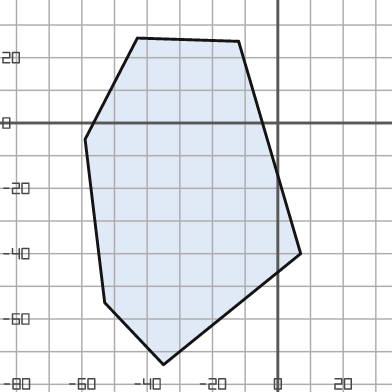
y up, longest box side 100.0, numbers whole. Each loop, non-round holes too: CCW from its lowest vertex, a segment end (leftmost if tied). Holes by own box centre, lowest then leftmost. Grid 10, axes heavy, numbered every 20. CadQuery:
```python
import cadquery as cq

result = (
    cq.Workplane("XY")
    .moveTo(-35.0, -74.0)
    .lineTo(7.0, -40.0)
    .lineTo(-12.0, 25.0)
    .lineTo(-43.0, 26.0)
    .lineTo(-59.0, -5.0)
    .lineTo(-53.0, -55.0)
    .close()
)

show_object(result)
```